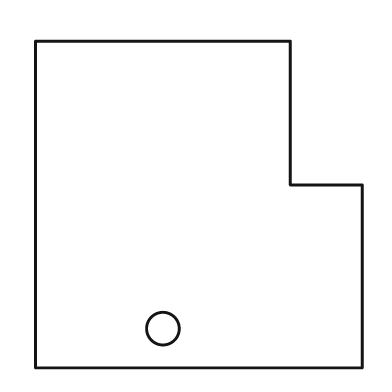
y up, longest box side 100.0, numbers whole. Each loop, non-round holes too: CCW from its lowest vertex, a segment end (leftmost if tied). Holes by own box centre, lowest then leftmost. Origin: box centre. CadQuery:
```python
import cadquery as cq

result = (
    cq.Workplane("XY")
    .moveTo(-50.0, -50.0)
    .lineTo(50.0, -50.0)
    .lineTo(50.0, 6.0)
    .lineTo(28.0, 6.0)
    .lineTo(28.0, 50.0)
    .lineTo(-50.0, 50.0)
    .close()
    .moveTo(-11.0, -38.0)
    .circle(5.0)
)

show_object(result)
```